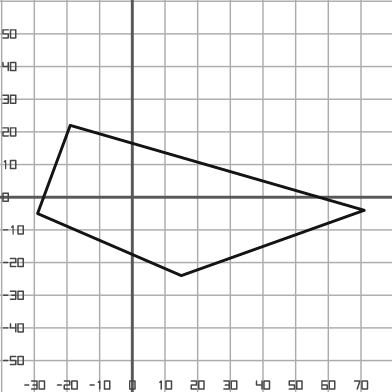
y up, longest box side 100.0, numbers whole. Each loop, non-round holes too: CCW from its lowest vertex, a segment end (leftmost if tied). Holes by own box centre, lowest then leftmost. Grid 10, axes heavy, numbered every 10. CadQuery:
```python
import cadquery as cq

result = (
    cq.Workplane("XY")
    .moveTo(15.0, -24.0)
    .lineTo(71.0, -4.0)
    .lineTo(-19.0, 22.0)
    .lineTo(-29.0, -5.0)
    .close()
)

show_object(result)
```